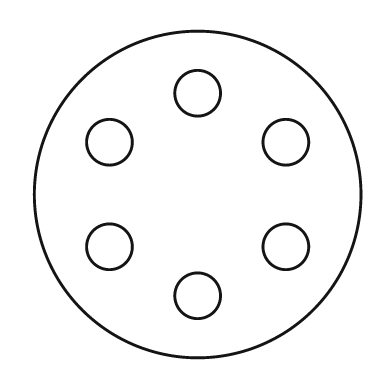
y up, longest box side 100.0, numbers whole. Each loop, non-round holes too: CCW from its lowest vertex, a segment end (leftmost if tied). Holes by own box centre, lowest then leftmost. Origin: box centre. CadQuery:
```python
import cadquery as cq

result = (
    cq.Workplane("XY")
    .moveTo(0.0, 0.0)
    .circle(50.0)
    .moveTo(0.0, -31.0)
    .circle(7.0)
    .moveTo(-27.0, -16.0)
    .circle(7.0)
    .moveTo(27.0, -16.0)
    .circle(7.0)
    .moveTo(-27.0, 16.0)
    .circle(7.0)
    .moveTo(27.0, 16.0)
    .circle(7.0)
    .moveTo(0.0, 31.0)
    .circle(7.0)
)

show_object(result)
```